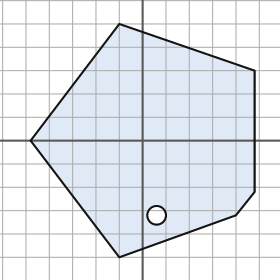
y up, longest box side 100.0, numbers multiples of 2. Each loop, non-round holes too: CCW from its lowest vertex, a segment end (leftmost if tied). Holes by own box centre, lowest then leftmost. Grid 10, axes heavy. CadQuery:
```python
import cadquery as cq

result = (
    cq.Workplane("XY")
    .moveTo(-10.0, -50.0)
    .lineTo(40.0, -32.0)
    .lineTo(48.0, -22.0)
    .lineTo(48.0, 30.0)
    .lineTo(-10.0, 50.0)
    .lineTo(-48.0, 0.0)
    .close()
    .moveTo(6.0, -32.0)
    .circle(4.0)
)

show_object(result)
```